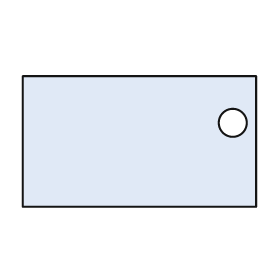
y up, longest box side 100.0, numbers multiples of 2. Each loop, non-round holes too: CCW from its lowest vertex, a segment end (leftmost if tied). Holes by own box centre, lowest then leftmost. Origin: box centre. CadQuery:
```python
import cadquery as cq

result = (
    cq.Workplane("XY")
    .moveTo(-50.0, -28.0)
    .lineTo(50.0, -28.0)
    .lineTo(50.0, 28.0)
    .lineTo(-50.0, 28.0)
    .close()
    .moveTo(40.0, 8.0)
    .circle(6.0)
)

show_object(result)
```